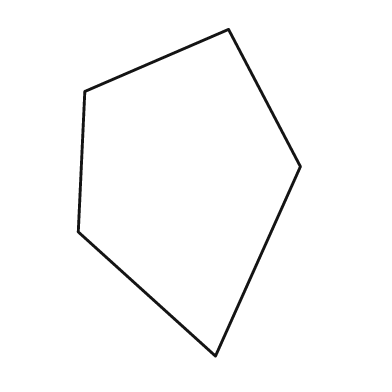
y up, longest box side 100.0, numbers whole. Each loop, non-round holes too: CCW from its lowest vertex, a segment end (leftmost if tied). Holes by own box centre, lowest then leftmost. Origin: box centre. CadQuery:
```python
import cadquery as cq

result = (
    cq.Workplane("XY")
    .moveTo(8.0, -50.0)
    .lineTo(34.0, 8.0)
    .lineTo(12.0, 50.0)
    .lineTo(-32.0, 31.0)
    .lineTo(-34.0, -12.0)
    .close()
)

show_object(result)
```